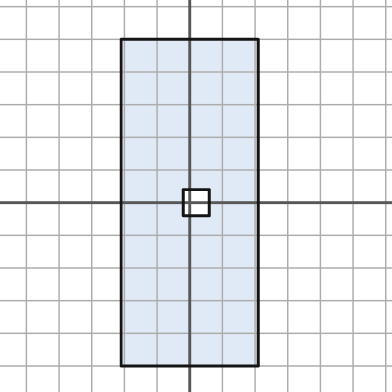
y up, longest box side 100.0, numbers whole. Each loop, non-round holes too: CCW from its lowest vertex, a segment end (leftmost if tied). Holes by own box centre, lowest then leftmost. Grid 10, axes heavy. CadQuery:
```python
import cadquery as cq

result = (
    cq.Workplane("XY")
    .moveTo(-21.0, -50.0)
    .lineTo(21.0, -50.0)
    .lineTo(21.0, 50.0)
    .lineTo(-21.0, 50.0)
    .close()
    .moveTo(-2.0, -4.0)
    .lineTo(6.0, -4.0)
    .lineTo(6.0, 4.0)
    .lineTo(-2.0, 4.0)
    .close()
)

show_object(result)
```